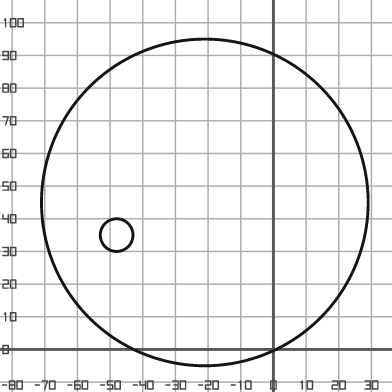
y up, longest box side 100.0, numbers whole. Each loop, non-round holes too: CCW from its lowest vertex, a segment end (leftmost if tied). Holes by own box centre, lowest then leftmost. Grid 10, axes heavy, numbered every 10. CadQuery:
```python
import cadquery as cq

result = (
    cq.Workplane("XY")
    .moveTo(-21.0, 45.0)
    .circle(50.0)
    .moveTo(-48.0, 35.0)
    .circle(5.0)
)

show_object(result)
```